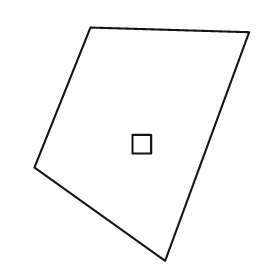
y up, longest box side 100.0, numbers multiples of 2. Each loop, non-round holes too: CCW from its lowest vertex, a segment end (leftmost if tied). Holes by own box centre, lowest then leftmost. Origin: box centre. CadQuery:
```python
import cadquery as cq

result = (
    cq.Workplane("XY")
    .moveTo(10.0, -50.0)
    .lineTo(46.0, 48.0)
    .lineTo(-22.0, 50.0)
    .lineTo(-46.0, -10.0)
    .close()
    .moveTo(-4.0, -4.0)
    .lineTo(4.0, -4.0)
    .lineTo(4.0, 4.0)
    .lineTo(-4.0, 4.0)
    .close()
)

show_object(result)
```